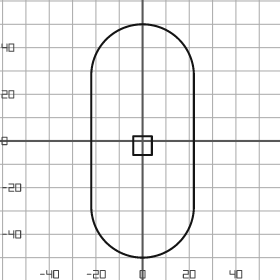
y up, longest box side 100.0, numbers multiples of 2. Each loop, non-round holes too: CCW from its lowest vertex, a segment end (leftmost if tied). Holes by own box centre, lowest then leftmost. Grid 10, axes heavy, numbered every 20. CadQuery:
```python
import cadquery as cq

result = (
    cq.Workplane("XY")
    .moveTo(-22.0, -28.0)
    .threePointArc((0.0, -50.0), (22.0, -28.0))
    .lineTo(22.0, 28.0)
    .threePointArc((0.0, 50.0), (-22.0, 28.0))
    .close()
    .moveTo(-4.0, -6.0)
    .lineTo(4.0, -6.0)
    .lineTo(4.0, 2.0)
    .lineTo(-4.0, 2.0)
    .close()
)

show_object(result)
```